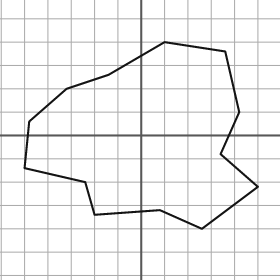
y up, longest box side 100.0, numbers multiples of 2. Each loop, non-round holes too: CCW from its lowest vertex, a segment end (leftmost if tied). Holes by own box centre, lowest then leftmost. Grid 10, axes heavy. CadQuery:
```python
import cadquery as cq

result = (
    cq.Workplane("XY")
    .moveTo(26.0, -40.0)
    .lineTo(50.0, -22.0)
    .lineTo(34.0, -8.0)
    .lineTo(42.0, 10.0)
    .lineTo(36.0, 36.0)
    .lineTo(10.0, 40.0)
    .lineTo(-14.0, 26.0)
    .lineTo(-32.0, 20.0)
    .lineTo(-48.0, 6.0)
    .lineTo(-50.0, -14.0)
    .lineTo(-24.0, -20.0)
    .lineTo(-20.0, -34.0)
    .lineTo(8.0, -32.0)
    .close()
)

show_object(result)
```